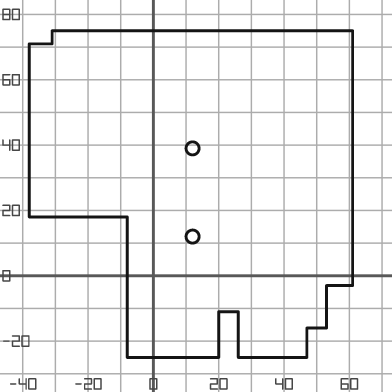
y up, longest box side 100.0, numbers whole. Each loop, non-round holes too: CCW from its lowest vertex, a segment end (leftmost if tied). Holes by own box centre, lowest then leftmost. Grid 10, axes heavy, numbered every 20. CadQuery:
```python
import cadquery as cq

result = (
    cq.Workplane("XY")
    .moveTo(-8.0, -25.0)
    .lineTo(20.0, -25.0)
    .lineTo(20.0, -11.0)
    .lineTo(26.0, -11.0)
    .lineTo(26.0, -25.0)
    .lineTo(47.0, -25.0)
    .lineTo(47.0, -16.0)
    .lineTo(53.0, -16.0)
    .lineTo(53.0, -3.0)
    .lineTo(61.0, -3.0)
    .lineTo(61.0, 75.0)
    .lineTo(-31.0, 75.0)
    .lineTo(-31.0, 71.0)
    .lineTo(-38.0, 71.0)
    .lineTo(-38.0, 18.0)
    .lineTo(-8.0, 18.0)
    .close()
    .moveTo(12.0, 12.0)
    .circle(2.0)
    .moveTo(12.0, 39.0)
    .circle(2.0)
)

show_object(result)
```